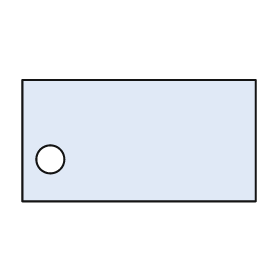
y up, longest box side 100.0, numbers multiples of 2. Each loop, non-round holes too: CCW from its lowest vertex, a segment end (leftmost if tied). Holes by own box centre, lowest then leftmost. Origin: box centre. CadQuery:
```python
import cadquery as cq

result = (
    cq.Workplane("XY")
    .moveTo(-50.0, -26.0)
    .lineTo(50.0, -26.0)
    .lineTo(50.0, 26.0)
    .lineTo(-50.0, 26.0)
    .close()
    .moveTo(-38.0, -8.0)
    .circle(6.0)
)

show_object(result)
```